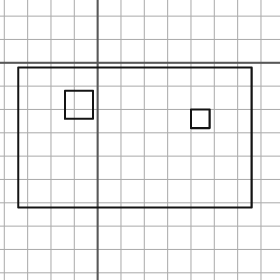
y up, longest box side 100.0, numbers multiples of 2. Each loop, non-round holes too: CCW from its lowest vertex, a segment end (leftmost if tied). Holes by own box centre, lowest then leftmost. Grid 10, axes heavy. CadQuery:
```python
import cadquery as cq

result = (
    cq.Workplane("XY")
    .moveTo(-34.0, -62.0)
    .lineTo(66.0, -62.0)
    .lineTo(66.0, -2.0)
    .lineTo(-34.0, -2.0)
    .close()
    .moveTo(40.0, -28.0)
    .lineTo(48.0, -28.0)
    .lineTo(48.0, -20.0)
    .lineTo(40.0, -20.0)
    .close()
    .moveTo(-14.0, -24.0)
    .lineTo(-2.0, -24.0)
    .lineTo(-2.0, -12.0)
    .lineTo(-14.0, -12.0)
    .close()
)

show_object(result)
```